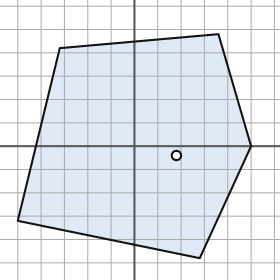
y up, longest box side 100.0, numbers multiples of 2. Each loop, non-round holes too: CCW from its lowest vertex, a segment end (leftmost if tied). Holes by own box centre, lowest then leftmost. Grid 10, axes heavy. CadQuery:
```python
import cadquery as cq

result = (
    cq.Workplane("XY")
    .moveTo(28.0, -48.0)
    .lineTo(50.0, 0.0)
    .lineTo(36.0, 48.0)
    .lineTo(-32.0, 42.0)
    .lineTo(-50.0, -32.0)
    .close()
    .moveTo(18.0, -4.0)
    .circle(2.0)
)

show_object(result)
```